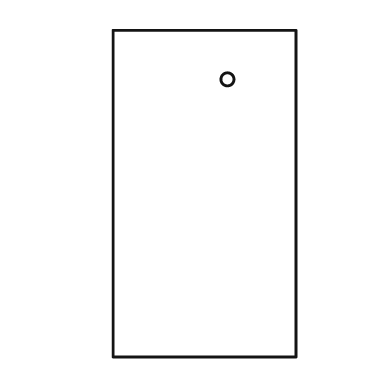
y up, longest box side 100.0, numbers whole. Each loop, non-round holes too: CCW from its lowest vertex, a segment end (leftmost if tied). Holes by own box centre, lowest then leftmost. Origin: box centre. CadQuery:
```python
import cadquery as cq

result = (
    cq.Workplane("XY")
    .moveTo(-28.0, -50.0)
    .lineTo(28.0, -50.0)
    .lineTo(28.0, 50.0)
    .lineTo(-28.0, 50.0)
    .close()
    .moveTo(7.0, 35.0)
    .circle(2.0)
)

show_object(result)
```